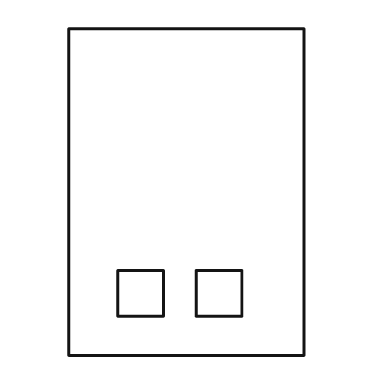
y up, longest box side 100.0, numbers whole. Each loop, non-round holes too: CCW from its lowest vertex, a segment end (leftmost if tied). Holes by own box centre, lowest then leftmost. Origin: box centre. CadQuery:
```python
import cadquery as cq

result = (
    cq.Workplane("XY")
    .moveTo(-36.0, -50.0)
    .lineTo(36.0, -50.0)
    .lineTo(36.0, 50.0)
    .lineTo(-36.0, 50.0)
    .close()
    .moveTo(-21.0, -38.0)
    .lineTo(-7.0, -38.0)
    .lineTo(-7.0, -24.0)
    .lineTo(-21.0, -24.0)
    .close()
    .moveTo(3.0, -38.0)
    .lineTo(17.0, -38.0)
    .lineTo(17.0, -24.0)
    .lineTo(3.0, -24.0)
    .close()
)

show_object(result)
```